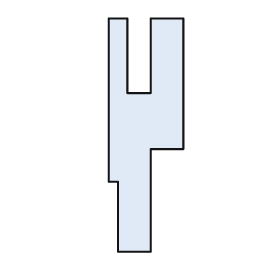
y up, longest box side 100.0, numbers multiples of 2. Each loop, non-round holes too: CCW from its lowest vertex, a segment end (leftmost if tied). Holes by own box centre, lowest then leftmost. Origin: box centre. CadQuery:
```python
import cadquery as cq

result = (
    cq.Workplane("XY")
    .moveTo(-12.0, -50.0)
    .lineTo(2.0, -50.0)
    .lineTo(2.0, -6.0)
    .lineTo(16.0, -6.0)
    .lineTo(16.0, 50.0)
    .lineTo(2.0, 50.0)
    .lineTo(2.0, 18.0)
    .lineTo(-8.0, 18.0)
    .lineTo(-8.0, 50.0)
    .lineTo(-16.0, 50.0)
    .lineTo(-16.0, -20.0)
    .lineTo(-12.0, -20.0)
    .close()
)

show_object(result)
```